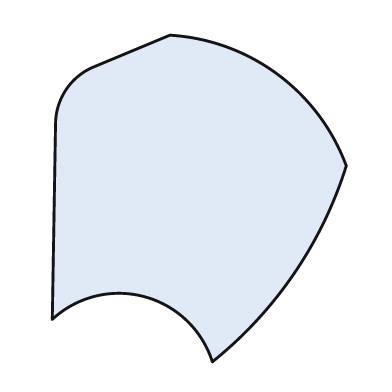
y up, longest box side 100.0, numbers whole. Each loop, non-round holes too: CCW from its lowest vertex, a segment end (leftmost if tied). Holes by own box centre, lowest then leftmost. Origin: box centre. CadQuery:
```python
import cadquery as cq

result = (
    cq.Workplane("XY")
    .moveTo(4.0, -50.0)
    .threePointArc((29.0, -23.0), (45.0, 10.0))
    .threePointArc((24.0, 38.0), (-9.0, 50.0))
    .lineTo(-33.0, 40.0)
    .threePointArc((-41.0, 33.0), (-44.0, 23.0))
    .lineTo(-45.0, -37.0)
    .threePointArc((-17.0, -30.0), (4.0, -50.0))
    .close()
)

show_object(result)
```